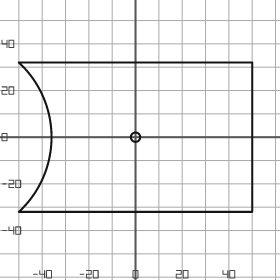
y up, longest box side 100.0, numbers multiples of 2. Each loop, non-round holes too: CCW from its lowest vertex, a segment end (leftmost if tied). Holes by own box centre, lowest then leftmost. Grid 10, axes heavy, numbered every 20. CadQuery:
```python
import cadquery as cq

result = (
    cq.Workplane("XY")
    .moveTo(-50.0, -32.0)
    .lineTo(50.0, -32.0)
    .lineTo(50.0, 32.0)
    .lineTo(-50.0, 32.0)
    .threePointArc((-36.0, 0.0), (-50.0, -32.0))
    .close()
    .moveTo(0.0, 0.0)
    .circle(2.0)
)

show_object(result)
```